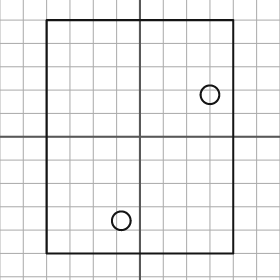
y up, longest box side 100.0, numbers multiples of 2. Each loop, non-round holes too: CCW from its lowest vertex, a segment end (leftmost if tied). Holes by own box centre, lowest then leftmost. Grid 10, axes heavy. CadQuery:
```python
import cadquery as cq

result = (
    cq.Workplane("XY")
    .moveTo(-40.0, -50.0)
    .lineTo(40.0, -50.0)
    .lineTo(40.0, 50.0)
    .lineTo(-40.0, 50.0)
    .close()
    .moveTo(-8.0, -36.0)
    .circle(4.0)
    .moveTo(30.0, 18.0)
    .circle(4.0)
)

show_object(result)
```